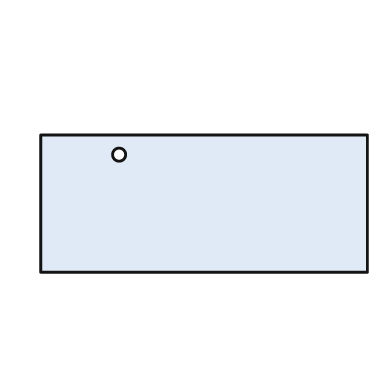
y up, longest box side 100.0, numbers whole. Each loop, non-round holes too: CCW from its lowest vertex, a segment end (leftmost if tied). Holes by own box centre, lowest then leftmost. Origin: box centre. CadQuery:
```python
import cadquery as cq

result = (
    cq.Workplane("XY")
    .moveTo(-50.0, -21.0)
    .lineTo(50.0, -21.0)
    .lineTo(50.0, 21.0)
    .lineTo(-50.0, 21.0)
    .close()
    .moveTo(-26.0, 15.0)
    .circle(2.0)
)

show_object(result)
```